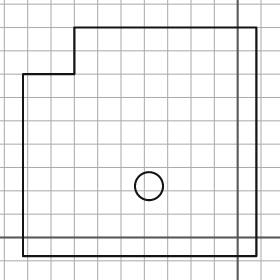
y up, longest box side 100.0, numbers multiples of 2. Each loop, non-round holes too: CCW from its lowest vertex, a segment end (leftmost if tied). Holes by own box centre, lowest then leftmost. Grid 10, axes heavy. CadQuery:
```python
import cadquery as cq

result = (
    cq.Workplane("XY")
    .moveTo(-92.0, -8.0)
    .lineTo(8.0, -8.0)
    .lineTo(8.0, 90.0)
    .lineTo(-70.0, 90.0)
    .lineTo(-70.0, 70.0)
    .lineTo(-92.0, 70.0)
    .close()
    .moveTo(-38.0, 22.0)
    .circle(6.0)
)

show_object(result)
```